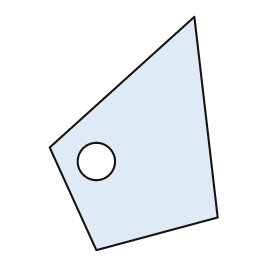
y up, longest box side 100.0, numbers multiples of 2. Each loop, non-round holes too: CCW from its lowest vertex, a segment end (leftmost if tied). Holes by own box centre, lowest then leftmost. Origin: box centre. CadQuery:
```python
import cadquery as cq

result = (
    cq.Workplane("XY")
    .moveTo(-16.0, -50.0)
    .lineTo(36.0, -36.0)
    .lineTo(26.0, 50.0)
    .lineTo(-36.0, -6.0)
    .close()
    .moveTo(-16.0, -12.0)
    .circle(8.0)
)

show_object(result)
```